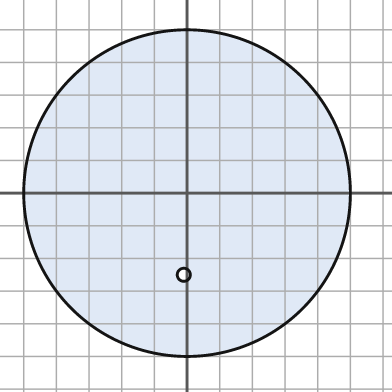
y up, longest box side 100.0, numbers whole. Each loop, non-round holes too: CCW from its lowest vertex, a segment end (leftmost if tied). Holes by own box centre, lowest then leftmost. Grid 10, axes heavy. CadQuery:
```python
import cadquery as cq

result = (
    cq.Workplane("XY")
    .moveTo(0.0, 0.0)
    .circle(50.0)
    .moveTo(-1.0, -25.0)
    .circle(2.0)
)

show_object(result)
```